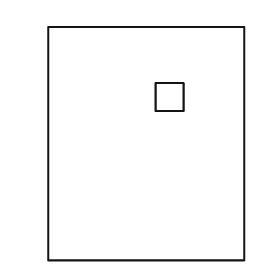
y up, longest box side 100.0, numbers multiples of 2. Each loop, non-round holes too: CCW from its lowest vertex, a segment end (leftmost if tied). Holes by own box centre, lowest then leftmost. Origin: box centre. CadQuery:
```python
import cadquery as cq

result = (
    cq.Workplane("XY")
    .moveTo(-42.0, -50.0)
    .lineTo(42.0, -50.0)
    .lineTo(42.0, 50.0)
    .lineTo(-42.0, 50.0)
    .close()
    .moveTo(4.0, 14.0)
    .lineTo(16.0, 14.0)
    .lineTo(16.0, 26.0)
    .lineTo(4.0, 26.0)
    .close()
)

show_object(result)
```